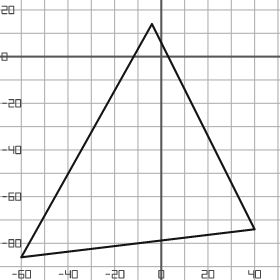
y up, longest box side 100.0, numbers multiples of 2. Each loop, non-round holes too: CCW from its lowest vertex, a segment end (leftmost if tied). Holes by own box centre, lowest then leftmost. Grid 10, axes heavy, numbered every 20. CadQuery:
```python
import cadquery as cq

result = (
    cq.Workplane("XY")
    .moveTo(-60.0, -86.0)
    .lineTo(40.0, -74.0)
    .lineTo(-4.0, 14.0)
    .close()
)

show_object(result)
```